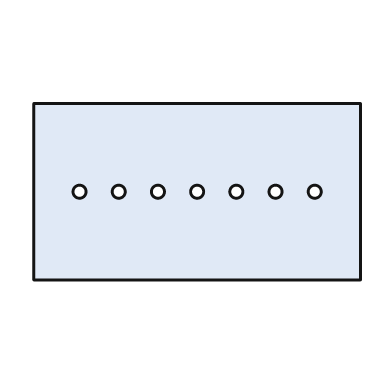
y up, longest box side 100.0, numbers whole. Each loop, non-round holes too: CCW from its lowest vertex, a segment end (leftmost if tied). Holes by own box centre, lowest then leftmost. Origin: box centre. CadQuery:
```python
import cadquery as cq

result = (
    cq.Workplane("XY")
    .moveTo(-50.0, -27.0)
    .lineTo(50.0, -27.0)
    .lineTo(50.0, 27.0)
    .lineTo(-50.0, 27.0)
    .close()
    .moveTo(-36.0, 0.0)
    .circle(2.0)
    .moveTo(-24.0, 0.0)
    .circle(2.0)
    .moveTo(-12.0, 0.0)
    .circle(2.0)
    .moveTo(0.0, 0.0)
    .circle(2.0)
    .moveTo(12.0, 0.0)
    .circle(2.0)
    .moveTo(24.0, 0.0)
    .circle(2.0)
    .moveTo(36.0, 0.0)
    .circle(2.0)
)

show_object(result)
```